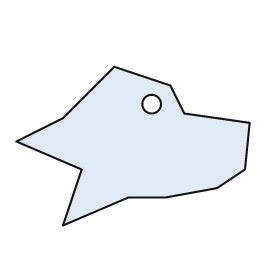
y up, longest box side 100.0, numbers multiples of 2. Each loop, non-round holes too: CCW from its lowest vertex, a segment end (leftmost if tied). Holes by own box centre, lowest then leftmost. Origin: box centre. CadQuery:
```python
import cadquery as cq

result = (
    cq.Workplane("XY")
    .moveTo(-30.0, -34.0)
    .lineTo(-2.0, -22.0)
    .lineTo(14.0, -22.0)
    .lineTo(36.0, -18.0)
    .lineTo(48.0, -10.0)
    .lineTo(50.0, 10.0)
    .lineTo(22.0, 14.0)
    .lineTo(16.0, 26.0)
    .lineTo(-8.0, 34.0)
    .lineTo(-30.0, 12.0)
    .lineTo(-50.0, 2.0)
    .lineTo(-22.0, -10.0)
    .close()
    .moveTo(8.0, 18.0)
    .circle(4.0)
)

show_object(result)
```